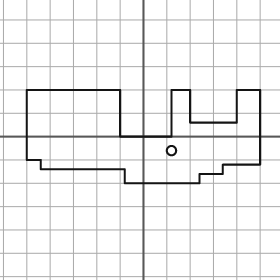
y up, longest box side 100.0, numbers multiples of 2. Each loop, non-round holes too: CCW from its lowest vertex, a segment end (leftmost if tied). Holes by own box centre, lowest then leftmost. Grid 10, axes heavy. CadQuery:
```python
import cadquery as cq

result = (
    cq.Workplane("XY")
    .moveTo(-8.0, -20.0)
    .lineTo(24.0, -20.0)
    .lineTo(24.0, -16.0)
    .lineTo(34.0, -16.0)
    .lineTo(34.0, -12.0)
    .lineTo(50.0, -12.0)
    .lineTo(50.0, 20.0)
    .lineTo(40.0, 20.0)
    .lineTo(40.0, 6.0)
    .lineTo(20.0, 6.0)
    .lineTo(20.0, 20.0)
    .lineTo(12.0, 20.0)
    .lineTo(12.0, 0.0)
    .lineTo(-10.0, 0.0)
    .lineTo(-10.0, 20.0)
    .lineTo(-50.0, 20.0)
    .lineTo(-50.0, -10.0)
    .lineTo(-44.0, -10.0)
    .lineTo(-44.0, -14.0)
    .lineTo(-8.0, -14.0)
    .close()
    .moveTo(12.0, -6.0)
    .circle(2.0)
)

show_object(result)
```